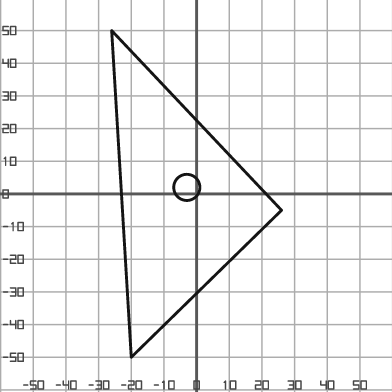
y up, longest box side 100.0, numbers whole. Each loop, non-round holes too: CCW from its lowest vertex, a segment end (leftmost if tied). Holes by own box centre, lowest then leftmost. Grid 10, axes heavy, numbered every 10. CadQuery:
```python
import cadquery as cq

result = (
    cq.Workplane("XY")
    .moveTo(-20.0, -50.0)
    .lineTo(26.0, -5.0)
    .lineTo(-26.0, 50.0)
    .close()
    .moveTo(-3.0, 2.0)
    .circle(4.0)
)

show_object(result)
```